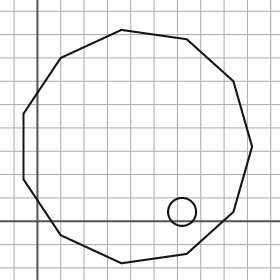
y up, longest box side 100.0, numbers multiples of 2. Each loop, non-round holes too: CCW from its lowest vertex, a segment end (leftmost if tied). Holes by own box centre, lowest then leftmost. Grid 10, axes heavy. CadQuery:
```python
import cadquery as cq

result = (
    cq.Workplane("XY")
    .moveTo(36.0, -18.0)
    .lineTo(64.0, -14.0)
    .lineTo(84.0, 4.0)
    .lineTo(92.0, 32.0)
    .lineTo(84.0, 60.0)
    .lineTo(64.0, 78.0)
    .lineTo(36.0, 82.0)
    .lineTo(10.0, 70.0)
    .lineTo(-6.0, 46.0)
    .lineTo(-6.0, 18.0)
    .lineTo(10.0, -6.0)
    .close()
    .moveTo(62.0, 4.0)
    .circle(6.0)
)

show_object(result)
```